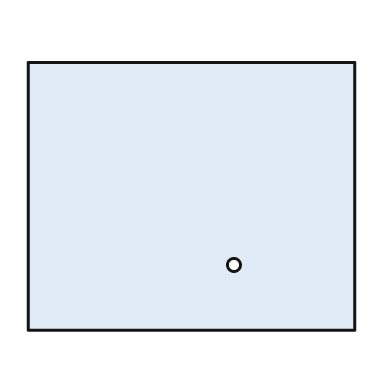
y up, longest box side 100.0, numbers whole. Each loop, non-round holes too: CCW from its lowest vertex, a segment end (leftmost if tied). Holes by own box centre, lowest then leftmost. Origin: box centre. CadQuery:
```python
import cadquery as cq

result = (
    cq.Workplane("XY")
    .moveTo(-50.0, -41.0)
    .lineTo(50.0, -41.0)
    .lineTo(50.0, 41.0)
    .lineTo(-50.0, 41.0)
    .close()
    .moveTo(13.0, -21.0)
    .circle(2.0)
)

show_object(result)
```